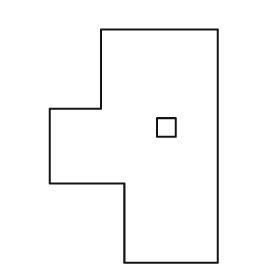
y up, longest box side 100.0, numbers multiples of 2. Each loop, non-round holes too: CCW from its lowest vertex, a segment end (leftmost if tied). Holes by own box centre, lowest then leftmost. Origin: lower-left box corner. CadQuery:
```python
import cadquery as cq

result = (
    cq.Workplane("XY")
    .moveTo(32.0, 0.0)
    .lineTo(72.0, 0.0)
    .lineTo(72.0, 100.0)
    .lineTo(22.0, 100.0)
    .lineTo(22.0, 66.0)
    .lineTo(0.0, 66.0)
    .lineTo(0.0, 34.0)
    .lineTo(32.0, 34.0)
    .close()
    .moveTo(46.0, 54.0)
    .lineTo(54.0, 54.0)
    .lineTo(54.0, 62.0)
    .lineTo(46.0, 62.0)
    .close()
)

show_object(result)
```